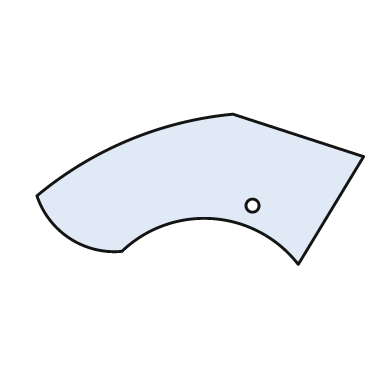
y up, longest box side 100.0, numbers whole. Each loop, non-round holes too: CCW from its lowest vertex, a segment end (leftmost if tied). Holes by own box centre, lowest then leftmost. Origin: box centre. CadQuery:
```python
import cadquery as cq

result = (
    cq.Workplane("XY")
    .moveTo(30.0, -23.0)
    .lineTo(50.0, 10.0)
    .lineTo(10.0, 23.0)
    .threePointArc((-22.0, 15.0), (-50.0, -2.0))
    .threePointArc((-40.0, -15.0), (-24.0, -19.0))
    .threePointArc((4.0, -9.0), (30.0, -23.0))
    .close()
    .moveTo(16.0, -5.0)
    .circle(2.0)
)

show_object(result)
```